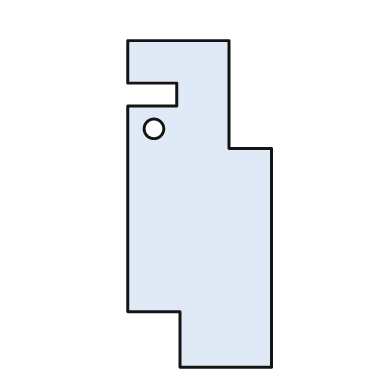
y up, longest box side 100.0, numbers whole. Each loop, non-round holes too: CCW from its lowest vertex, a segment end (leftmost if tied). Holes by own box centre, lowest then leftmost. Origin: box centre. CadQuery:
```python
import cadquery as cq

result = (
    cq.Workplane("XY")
    .moveTo(-6.0, -50.0)
    .lineTo(22.0, -50.0)
    .lineTo(22.0, 17.0)
    .lineTo(9.0, 17.0)
    .lineTo(9.0, 50.0)
    .lineTo(-22.0, 50.0)
    .lineTo(-22.0, 37.0)
    .lineTo(-7.0, 37.0)
    .lineTo(-7.0, 30.0)
    .lineTo(-22.0, 30.0)
    .lineTo(-22.0, -33.0)
    .lineTo(-6.0, -33.0)
    .close()
    .moveTo(-14.0, 23.0)
    .circle(3.0)
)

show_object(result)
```